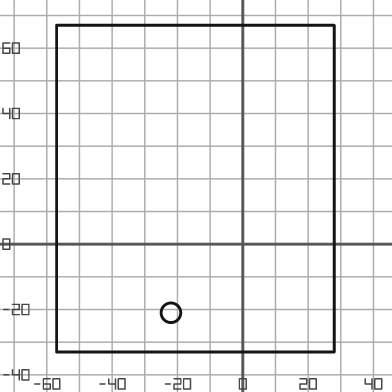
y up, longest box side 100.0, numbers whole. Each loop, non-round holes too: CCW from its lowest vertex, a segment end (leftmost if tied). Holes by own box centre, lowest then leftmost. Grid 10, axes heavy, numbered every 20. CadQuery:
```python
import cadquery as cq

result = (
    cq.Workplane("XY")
    .moveTo(-57.0, -33.0)
    .lineTo(28.0, -33.0)
    .lineTo(28.0, 67.0)
    .lineTo(-57.0, 67.0)
    .close()
    .moveTo(-22.0, -21.0)
    .circle(3.0)
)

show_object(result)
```